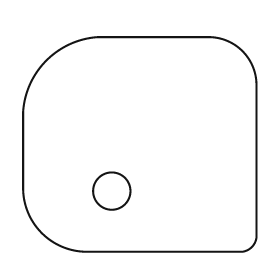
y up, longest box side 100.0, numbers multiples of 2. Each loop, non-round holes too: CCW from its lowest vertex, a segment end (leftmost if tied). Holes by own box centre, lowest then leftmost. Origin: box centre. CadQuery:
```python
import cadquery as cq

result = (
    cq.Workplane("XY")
    .moveTo(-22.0, -46.0)
    .lineTo(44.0, -46.0)
    .threePointArc((48.0, -44.0), (50.0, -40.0))
    .lineTo(50.0, 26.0)
    .threePointArc((44.0, 40.0), (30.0, 46.0))
    .lineTo(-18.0, 46.0)
    .threePointArc((-40.0, 36.0), (-50.0, 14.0))
    .lineTo(-50.0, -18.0)
    .threePointArc((-42.0, -38.0), (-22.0, -46.0))
    .close()
    .moveTo(-12.0, -20.0)
    .circle(8.0)
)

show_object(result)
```